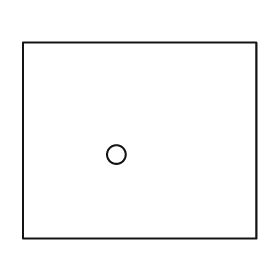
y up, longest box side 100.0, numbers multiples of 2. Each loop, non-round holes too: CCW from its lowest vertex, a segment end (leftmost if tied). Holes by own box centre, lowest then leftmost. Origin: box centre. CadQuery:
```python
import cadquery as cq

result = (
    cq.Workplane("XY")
    .moveTo(-50.0, -42.0)
    .lineTo(50.0, -42.0)
    .lineTo(50.0, 42.0)
    .lineTo(-50.0, 42.0)
    .close()
    .moveTo(-10.0, -6.0)
    .circle(4.0)
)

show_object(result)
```